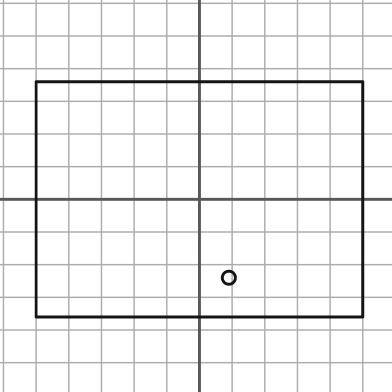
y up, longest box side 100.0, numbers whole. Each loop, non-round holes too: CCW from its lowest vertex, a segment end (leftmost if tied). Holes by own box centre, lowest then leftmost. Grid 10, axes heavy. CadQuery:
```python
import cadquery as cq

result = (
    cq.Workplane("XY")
    .moveTo(-50.0, -36.0)
    .lineTo(50.0, -36.0)
    .lineTo(50.0, 36.0)
    .lineTo(-50.0, 36.0)
    .close()
    .moveTo(9.0, -24.0)
    .circle(2.0)
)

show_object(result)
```